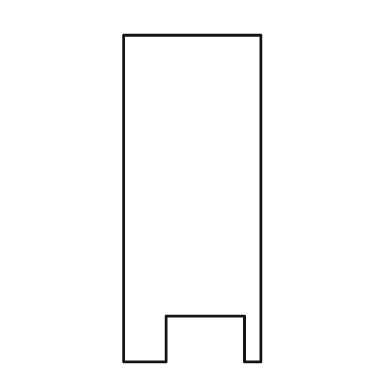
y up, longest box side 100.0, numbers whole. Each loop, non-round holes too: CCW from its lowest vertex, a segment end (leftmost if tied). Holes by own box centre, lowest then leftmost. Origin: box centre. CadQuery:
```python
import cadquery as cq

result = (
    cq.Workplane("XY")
    .moveTo(-21.0, -50.0)
    .lineTo(-8.0, -50.0)
    .lineTo(-8.0, -36.0)
    .lineTo(16.0, -36.0)
    .lineTo(16.0, -50.0)
    .lineTo(21.0, -50.0)
    .lineTo(21.0, 50.0)
    .lineTo(-21.0, 50.0)
    .close()
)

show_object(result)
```